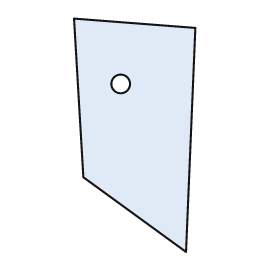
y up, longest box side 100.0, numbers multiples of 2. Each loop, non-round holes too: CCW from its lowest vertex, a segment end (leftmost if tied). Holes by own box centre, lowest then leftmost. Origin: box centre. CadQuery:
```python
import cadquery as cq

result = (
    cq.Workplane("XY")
    .moveTo(22.0, -50.0)
    .lineTo(26.0, 46.0)
    .lineTo(-26.0, 50.0)
    .lineTo(-22.0, -18.0)
    .close()
    .moveTo(-6.0, 22.0)
    .circle(4.0)
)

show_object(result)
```